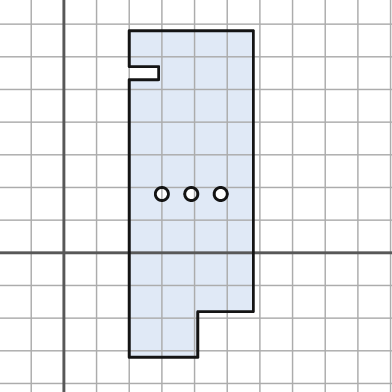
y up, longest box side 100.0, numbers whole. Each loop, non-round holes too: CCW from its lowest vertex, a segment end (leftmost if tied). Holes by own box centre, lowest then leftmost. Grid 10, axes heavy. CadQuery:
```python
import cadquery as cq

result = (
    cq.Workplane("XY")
    .moveTo(20.0, -32.0)
    .lineTo(41.0, -32.0)
    .lineTo(41.0, -18.0)
    .lineTo(58.0, -18.0)
    .lineTo(58.0, 68.0)
    .lineTo(20.0, 68.0)
    .lineTo(20.0, 57.0)
    .lineTo(29.0, 57.0)
    .lineTo(29.0, 53.0)
    .lineTo(20.0, 53.0)
    .close()
    .moveTo(30.0, 18.0)
    .circle(2.0)
    .moveTo(39.0, 18.0)
    .circle(2.0)
    .moveTo(48.0, 18.0)
    .circle(2.0)
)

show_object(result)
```